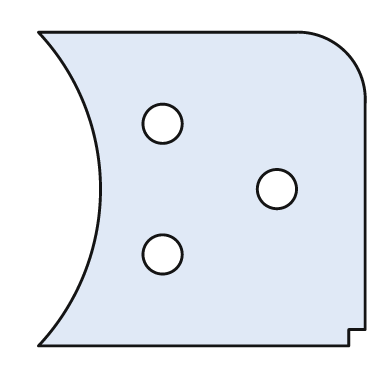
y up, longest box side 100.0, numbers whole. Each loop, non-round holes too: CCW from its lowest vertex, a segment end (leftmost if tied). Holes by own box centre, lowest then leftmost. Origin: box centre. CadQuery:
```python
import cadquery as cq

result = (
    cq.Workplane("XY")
    .moveTo(-50.0, -48.0)
    .lineTo(45.0, -48.0)
    .lineTo(45.0, -43.0)
    .lineTo(50.0, -43.0)
    .lineTo(50.0, 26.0)
    .threePointArc((44.0, 42.0), (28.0, 48.0))
    .lineTo(-50.0, 48.0)
    .threePointArc((-31.0, 0.0), (-50.0, -48.0))
    .close()
    .moveTo(-12.0, -20.0)
    .circle(6.0)
    .moveTo(23.0, 0.0)
    .circle(6.0)
    .moveTo(-12.0, 20.0)
    .circle(6.0)
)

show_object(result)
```